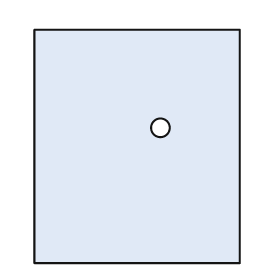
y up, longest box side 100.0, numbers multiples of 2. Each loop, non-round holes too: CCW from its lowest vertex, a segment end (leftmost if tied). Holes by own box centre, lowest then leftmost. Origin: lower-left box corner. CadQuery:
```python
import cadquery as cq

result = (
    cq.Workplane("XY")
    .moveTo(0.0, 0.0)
    .lineTo(88.0, 0.0)
    .lineTo(88.0, 100.0)
    .lineTo(0.0, 100.0)
    .close()
    .moveTo(54.0, 58.0)
    .circle(4.0)
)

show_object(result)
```